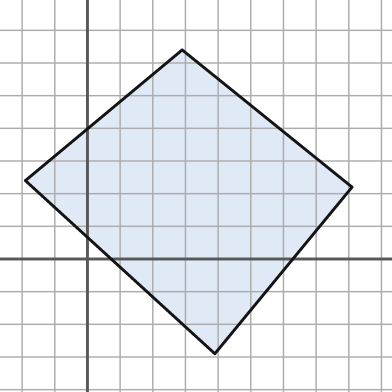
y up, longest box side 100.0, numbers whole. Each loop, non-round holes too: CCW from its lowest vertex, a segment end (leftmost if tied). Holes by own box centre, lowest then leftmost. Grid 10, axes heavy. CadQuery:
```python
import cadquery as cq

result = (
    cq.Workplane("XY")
    .moveTo(39.0, -29.0)
    .lineTo(81.0, 22.0)
    .lineTo(29.0, 64.0)
    .lineTo(-19.0, 24.0)
    .close()
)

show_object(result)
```